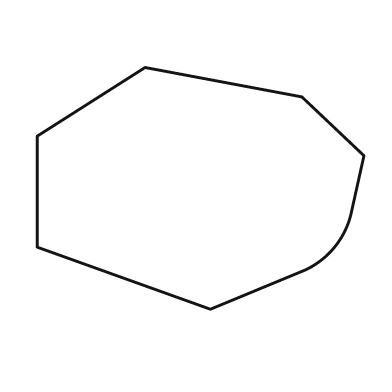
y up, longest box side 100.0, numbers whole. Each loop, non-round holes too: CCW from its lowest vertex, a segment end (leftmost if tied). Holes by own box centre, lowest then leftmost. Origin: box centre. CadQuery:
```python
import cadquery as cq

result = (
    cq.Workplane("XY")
    .moveTo(3.0, -37.0)
    .lineTo(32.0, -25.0)
    .threePointArc((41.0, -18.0), (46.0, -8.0))
    .lineTo(50.0, 10.0)
    .lineTo(31.0, 28.0)
    .lineTo(-17.0, 37.0)
    .lineTo(-50.0, 16.0)
    .lineTo(-50.0, -18.0)
    .close()
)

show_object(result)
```